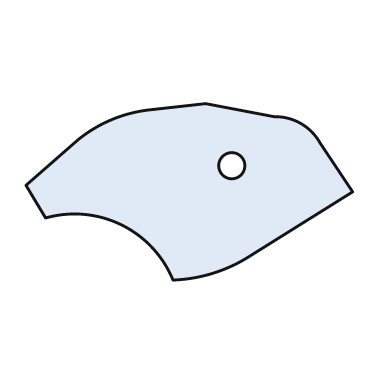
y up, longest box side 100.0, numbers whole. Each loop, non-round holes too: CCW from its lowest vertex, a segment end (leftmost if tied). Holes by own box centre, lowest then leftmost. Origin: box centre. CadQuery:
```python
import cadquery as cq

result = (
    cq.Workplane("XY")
    .moveTo(-5.0, -27.0)
    .threePointArc((7.0, -25.0), (18.0, -20.0))
    .lineTo(50.0, 0.0)
    .lineTo(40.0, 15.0)
    .threePointArc((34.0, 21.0), (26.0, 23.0))
    .lineTo(5.0, 27.0)
    .lineTo(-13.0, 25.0)
    .threePointArc((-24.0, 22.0), (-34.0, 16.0))
    .lineTo(-50.0, 2.0)
    .lineTo(-44.0, -8.0)
    .threePointArc((-21.0, -10.0), (-5.0, -27.0))
    .close()
    .moveTo(13.0, 8.0)
    .circle(4.0)
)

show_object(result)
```